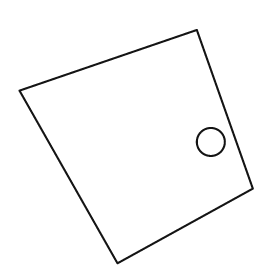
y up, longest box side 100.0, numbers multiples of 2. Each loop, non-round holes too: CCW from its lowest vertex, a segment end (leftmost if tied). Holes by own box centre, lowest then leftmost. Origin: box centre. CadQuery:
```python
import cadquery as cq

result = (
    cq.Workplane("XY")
    .moveTo(-8.0, -50.0)
    .lineTo(50.0, -18.0)
    .lineTo(26.0, 50.0)
    .lineTo(-50.0, 24.0)
    .close()
    .moveTo(32.0, 2.0)
    .circle(6.0)
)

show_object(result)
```